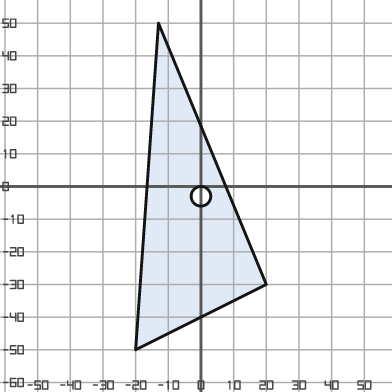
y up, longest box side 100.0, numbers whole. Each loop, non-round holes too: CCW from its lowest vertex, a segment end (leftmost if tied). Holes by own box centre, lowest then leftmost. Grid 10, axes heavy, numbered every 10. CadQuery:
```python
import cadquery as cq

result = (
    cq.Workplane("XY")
    .moveTo(-20.0, -50.0)
    .lineTo(20.0, -30.0)
    .lineTo(-13.0, 50.0)
    .close()
    .moveTo(0.0, -3.0)
    .circle(3.0)
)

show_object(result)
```